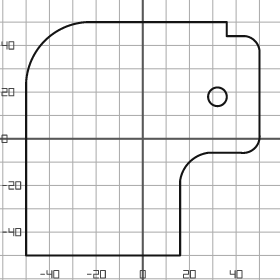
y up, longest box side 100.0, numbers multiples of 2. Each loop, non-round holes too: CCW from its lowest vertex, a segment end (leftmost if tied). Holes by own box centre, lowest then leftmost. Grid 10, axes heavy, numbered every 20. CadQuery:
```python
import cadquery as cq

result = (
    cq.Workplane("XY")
    .moveTo(-50.0, -50.0)
    .lineTo(16.0, -50.0)
    .lineTo(16.0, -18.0)
    .threePointArc((20.0, -10.0), (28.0, -6.0))
    .lineTo(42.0, -6.0)
    .threePointArc((48.0, -4.0), (50.0, 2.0))
    .lineTo(50.0, 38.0)
    .threePointArc((48.0, 42.0), (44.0, 44.0))
    .lineTo(36.0, 44.0)
    .lineTo(36.0, 50.0)
    .lineTo(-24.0, 50.0)
    .threePointArc((-42.0, 42.0), (-50.0, 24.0))
    .close()
    .moveTo(32.0, 18.0)
    .circle(4.0)
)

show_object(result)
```